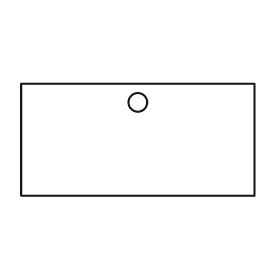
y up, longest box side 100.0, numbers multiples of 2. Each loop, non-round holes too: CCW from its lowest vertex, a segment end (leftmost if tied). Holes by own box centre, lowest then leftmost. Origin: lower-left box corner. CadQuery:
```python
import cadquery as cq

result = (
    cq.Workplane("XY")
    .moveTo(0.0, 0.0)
    .lineTo(100.0, 0.0)
    .lineTo(100.0, 48.0)
    .lineTo(0.0, 48.0)
    .close()
    .moveTo(50.0, 40.0)
    .circle(4.0)
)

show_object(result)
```